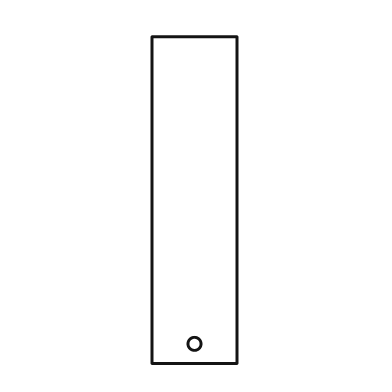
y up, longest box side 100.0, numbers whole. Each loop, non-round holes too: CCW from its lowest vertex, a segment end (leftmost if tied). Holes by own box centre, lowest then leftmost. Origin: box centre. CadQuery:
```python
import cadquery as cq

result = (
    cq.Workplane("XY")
    .moveTo(-13.0, -50.0)
    .lineTo(13.0, -50.0)
    .lineTo(13.0, 50.0)
    .lineTo(-13.0, 50.0)
    .close()
    .moveTo(0.0, -44.0)
    .circle(2.0)
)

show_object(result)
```